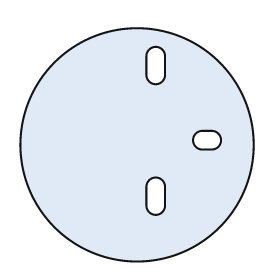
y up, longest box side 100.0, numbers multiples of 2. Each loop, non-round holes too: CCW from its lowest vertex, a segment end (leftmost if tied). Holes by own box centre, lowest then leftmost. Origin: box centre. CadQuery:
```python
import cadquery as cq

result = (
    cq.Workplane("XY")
    .moveTo(0.0, 0.0)
    .circle(50.0)
    .moveTo(4.0, -26.0)
    .threePointArc((8.0, -30.0), (12.0, -26.0))
    .lineTo(12.0, -18.0)
    .threePointArc((8.0, -14.0), (4.0, -18.0))
    .close()
    .moveTo(28.0, -2.0)
    .lineTo(32.0, -2.0)
    .threePointArc((36.0, 2.0), (32.0, 6.0))
    .lineTo(28.0, 6.0)
    .threePointArc((24.0, 2.0), (28.0, -2.0))
    .close()
    .moveTo(4.0, 30.0)
    .threePointArc((8.0, 26.0), (12.0, 30.0))
    .lineTo(12.0, 38.0)
    .threePointArc((8.0, 42.0), (4.0, 38.0))
    .close()
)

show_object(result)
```